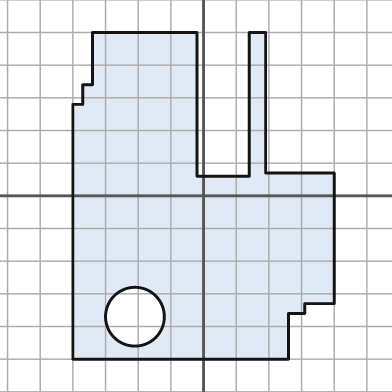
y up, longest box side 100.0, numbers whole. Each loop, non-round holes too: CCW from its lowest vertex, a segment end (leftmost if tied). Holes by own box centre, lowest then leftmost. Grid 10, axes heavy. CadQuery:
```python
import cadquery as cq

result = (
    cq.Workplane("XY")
    .moveTo(-40.0, -50.0)
    .lineTo(26.0, -50.0)
    .lineTo(26.0, -36.0)
    .lineTo(31.0, -36.0)
    .lineTo(31.0, -33.0)
    .lineTo(40.0, -33.0)
    .lineTo(40.0, 7.0)
    .lineTo(19.0, 7.0)
    .lineTo(19.0, 50.0)
    .lineTo(14.0, 50.0)
    .lineTo(14.0, 6.0)
    .lineTo(-2.0, 6.0)
    .lineTo(-2.0, 50.0)
    .lineTo(-34.0, 50.0)
    .lineTo(-34.0, 34.0)
    .lineTo(-37.0, 34.0)
    .lineTo(-37.0, 28.0)
    .lineTo(-40.0, 28.0)
    .close()
    .moveTo(-21.0, -37.0)
    .circle(9.0)
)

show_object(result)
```